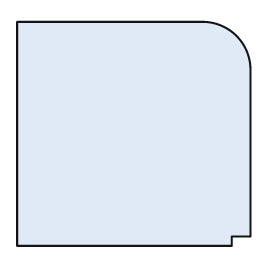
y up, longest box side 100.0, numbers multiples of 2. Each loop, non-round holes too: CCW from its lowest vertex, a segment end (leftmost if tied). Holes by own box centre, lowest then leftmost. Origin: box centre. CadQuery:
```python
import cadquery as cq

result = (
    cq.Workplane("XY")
    .moveTo(-50.0, -48.0)
    .lineTo(42.0, -48.0)
    .lineTo(42.0, -44.0)
    .lineTo(50.0, -44.0)
    .lineTo(50.0, 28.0)
    .threePointArc((44.0, 42.0), (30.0, 48.0))
    .lineTo(-50.0, 48.0)
    .close()
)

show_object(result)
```